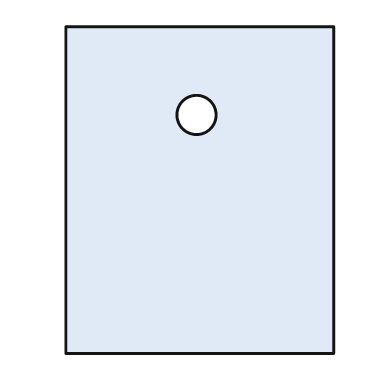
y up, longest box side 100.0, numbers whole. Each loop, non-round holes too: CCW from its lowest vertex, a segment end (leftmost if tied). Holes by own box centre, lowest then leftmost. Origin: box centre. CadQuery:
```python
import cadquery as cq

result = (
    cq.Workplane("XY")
    .moveTo(-41.0, -50.0)
    .lineTo(41.0, -50.0)
    .lineTo(41.0, 50.0)
    .lineTo(-41.0, 50.0)
    .close()
    .moveTo(-1.0, 23.0)
    .circle(6.0)
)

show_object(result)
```